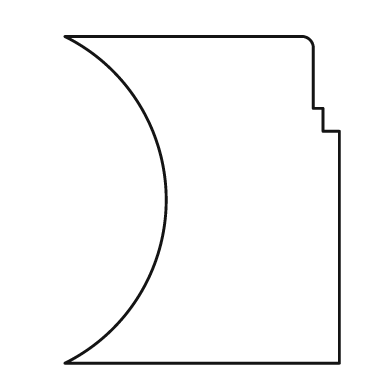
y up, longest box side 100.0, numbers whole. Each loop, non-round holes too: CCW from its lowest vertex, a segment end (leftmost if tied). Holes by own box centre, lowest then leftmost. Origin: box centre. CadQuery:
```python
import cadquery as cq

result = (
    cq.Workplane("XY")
    .moveTo(-42.0, -50.0)
    .lineTo(42.0, -50.0)
    .lineTo(42.0, 21.0)
    .lineTo(37.0, 21.0)
    .lineTo(37.0, 28.0)
    .lineTo(34.0, 28.0)
    .lineTo(34.0, 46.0)
    .threePointArc((33.0, 49.0), (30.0, 50.0))
    .lineTo(-42.0, 50.0)
    .threePointArc((-11.0, 0.0), (-42.0, -50.0))
    .close()
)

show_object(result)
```